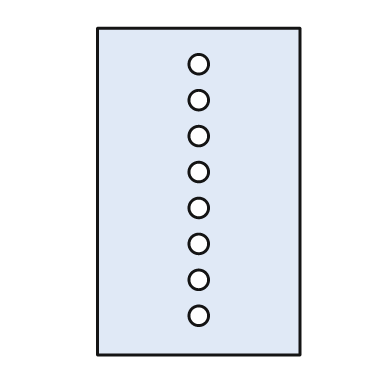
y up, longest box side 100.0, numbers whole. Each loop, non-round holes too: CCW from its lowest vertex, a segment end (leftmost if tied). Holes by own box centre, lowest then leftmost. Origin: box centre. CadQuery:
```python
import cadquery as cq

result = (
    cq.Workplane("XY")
    .moveTo(-31.0, -50.0)
    .lineTo(31.0, -50.0)
    .lineTo(31.0, 50.0)
    .lineTo(-31.0, 50.0)
    .close()
    .moveTo(0.0, -38.0)
    .circle(3.0)
    .moveTo(0.0, -27.0)
    .circle(3.0)
    .moveTo(0.0, -16.0)
    .circle(3.0)
    .moveTo(0.0, -5.0)
    .circle(3.0)
    .moveTo(0.0, 6.0)
    .circle(3.0)
    .moveTo(0.0, 17.0)
    .circle(3.0)
    .moveTo(0.0, 28.0)
    .circle(3.0)
    .moveTo(0.0, 39.0)
    .circle(3.0)
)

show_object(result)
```